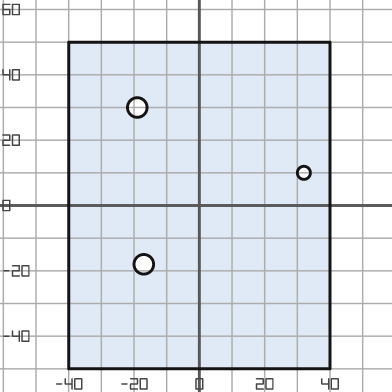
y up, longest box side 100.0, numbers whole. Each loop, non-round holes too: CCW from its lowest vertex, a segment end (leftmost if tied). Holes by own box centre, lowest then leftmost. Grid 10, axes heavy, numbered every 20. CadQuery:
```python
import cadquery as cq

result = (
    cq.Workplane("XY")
    .moveTo(-40.0, -50.0)
    .lineTo(40.0, -50.0)
    .lineTo(40.0, 50.0)
    .lineTo(-40.0, 50.0)
    .close()
    .moveTo(-17.0, -18.0)
    .circle(3.0)
    .moveTo(32.0, 10.0)
    .circle(2.0)
    .moveTo(-19.0, 30.0)
    .circle(3.0)
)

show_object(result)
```